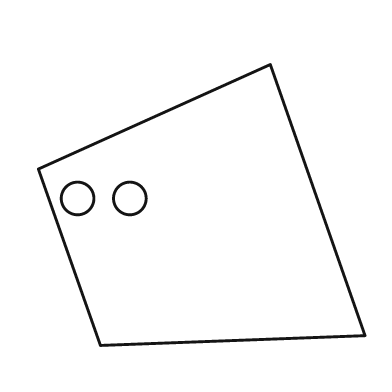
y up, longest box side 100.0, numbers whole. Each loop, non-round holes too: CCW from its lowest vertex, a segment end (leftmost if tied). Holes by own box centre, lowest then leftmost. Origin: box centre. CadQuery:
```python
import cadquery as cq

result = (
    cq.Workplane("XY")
    .moveTo(-31.0, -43.0)
    .lineTo(50.0, -40.0)
    .lineTo(21.0, 43.0)
    .lineTo(-50.0, 11.0)
    .close()
    .moveTo(-38.0, 2.0)
    .circle(5.0)
    .moveTo(-22.0, 2.0)
    .circle(5.0)
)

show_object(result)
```